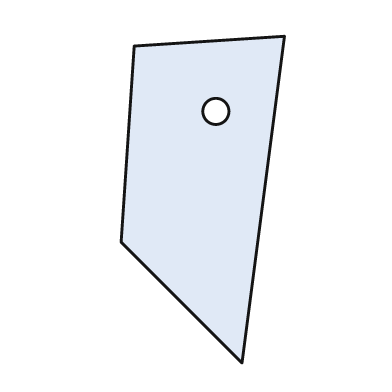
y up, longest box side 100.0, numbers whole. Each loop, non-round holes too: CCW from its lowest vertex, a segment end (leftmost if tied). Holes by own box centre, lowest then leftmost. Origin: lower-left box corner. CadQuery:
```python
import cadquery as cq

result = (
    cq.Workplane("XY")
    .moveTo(37.0, 0.0)
    .lineTo(50.0, 100.0)
    .lineTo(4.0, 97.0)
    .lineTo(0.0, 37.0)
    .close()
    .moveTo(29.0, 77.0)
    .circle(4.0)
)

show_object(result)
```